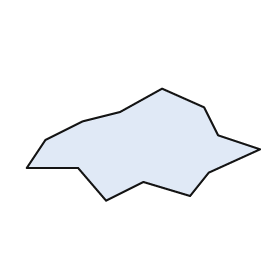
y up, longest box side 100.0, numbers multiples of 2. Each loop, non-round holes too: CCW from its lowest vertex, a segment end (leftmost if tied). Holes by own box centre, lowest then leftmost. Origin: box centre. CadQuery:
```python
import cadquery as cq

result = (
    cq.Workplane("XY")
    .moveTo(-16.0, -24.0)
    .lineTo(0.0, -16.0)
    .lineTo(20.0, -22.0)
    .lineTo(28.0, -12.0)
    .lineTo(50.0, -2.0)
    .lineTo(32.0, 4.0)
    .lineTo(26.0, 16.0)
    .lineTo(8.0, 24.0)
    .lineTo(-10.0, 14.0)
    .lineTo(-26.0, 10.0)
    .lineTo(-42.0, 2.0)
    .lineTo(-50.0, -10.0)
    .lineTo(-28.0, -10.0)
    .close()
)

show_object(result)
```